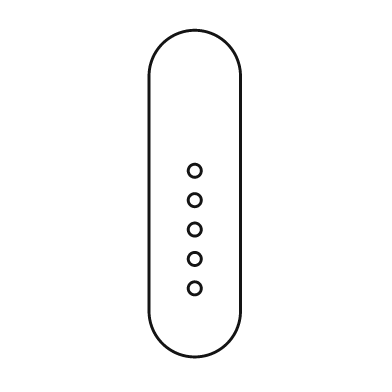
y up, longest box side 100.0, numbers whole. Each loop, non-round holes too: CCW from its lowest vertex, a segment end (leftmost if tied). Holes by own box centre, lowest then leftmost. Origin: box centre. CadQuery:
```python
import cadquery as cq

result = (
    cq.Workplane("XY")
    .moveTo(-14.0, -36.0)
    .threePointArc((0.0, -50.0), (14.0, -36.0))
    .lineTo(14.0, 36.0)
    .threePointArc((0.0, 50.0), (-14.0, 36.0))
    .close()
    .moveTo(0.0, -29.0)
    .circle(2.0)
    .moveTo(0.0, -20.0)
    .circle(2.0)
    .moveTo(0.0, -11.0)
    .circle(2.0)
    .moveTo(0.0, -2.0)
    .circle(2.0)
    .moveTo(0.0, 7.0)
    .circle(2.0)
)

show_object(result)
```